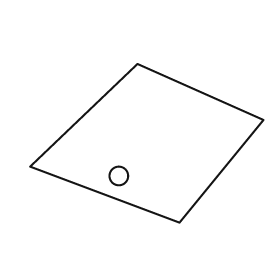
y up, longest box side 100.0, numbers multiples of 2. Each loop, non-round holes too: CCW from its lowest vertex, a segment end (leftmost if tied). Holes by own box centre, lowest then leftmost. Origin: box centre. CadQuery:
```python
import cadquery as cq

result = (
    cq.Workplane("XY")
    .moveTo(14.0, -34.0)
    .lineTo(50.0, 10.0)
    .lineTo(-4.0, 34.0)
    .lineTo(-50.0, -10.0)
    .close()
    .moveTo(-12.0, -14.0)
    .circle(4.0)
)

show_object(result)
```